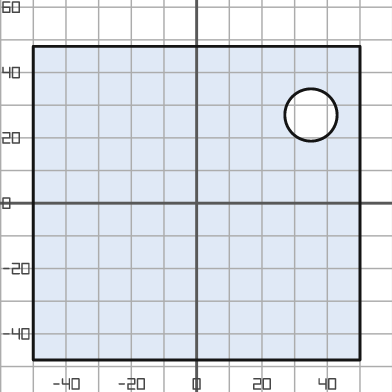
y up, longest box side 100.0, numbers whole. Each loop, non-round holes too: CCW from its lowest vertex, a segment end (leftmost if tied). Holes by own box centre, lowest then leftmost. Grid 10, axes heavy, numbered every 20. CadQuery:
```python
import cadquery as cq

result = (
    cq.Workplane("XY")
    .moveTo(-50.0, -48.0)
    .lineTo(50.0, -48.0)
    .lineTo(50.0, 48.0)
    .lineTo(-50.0, 48.0)
    .close()
    .moveTo(35.0, 27.0)
    .circle(8.0)
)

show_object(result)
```